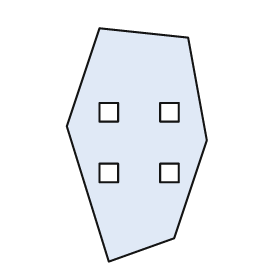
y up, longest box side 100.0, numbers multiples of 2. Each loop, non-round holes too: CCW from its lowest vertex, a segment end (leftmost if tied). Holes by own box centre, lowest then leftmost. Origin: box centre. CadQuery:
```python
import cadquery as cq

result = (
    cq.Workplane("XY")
    .moveTo(-12.0, -50.0)
    .lineTo(16.0, -40.0)
    .lineTo(30.0, 2.0)
    .lineTo(22.0, 46.0)
    .lineTo(-16.0, 50.0)
    .lineTo(-30.0, 8.0)
    .close()
    .moveTo(-16.0, -16.0)
    .lineTo(-8.0, -16.0)
    .lineTo(-8.0, -8.0)
    .lineTo(-16.0, -8.0)
    .close()
    .moveTo(10.0, -16.0)
    .lineTo(18.0, -16.0)
    .lineTo(18.0, -8.0)
    .lineTo(10.0, -8.0)
    .close()
    .moveTo(-16.0, 10.0)
    .lineTo(-8.0, 10.0)
    .lineTo(-8.0, 18.0)
    .lineTo(-16.0, 18.0)
    .close()
    .moveTo(10.0, 10.0)
    .lineTo(18.0, 10.0)
    .lineTo(18.0, 18.0)
    .lineTo(10.0, 18.0)
    .close()
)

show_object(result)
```